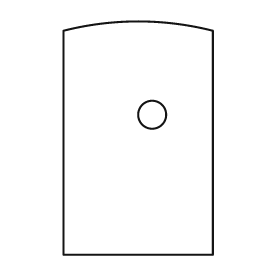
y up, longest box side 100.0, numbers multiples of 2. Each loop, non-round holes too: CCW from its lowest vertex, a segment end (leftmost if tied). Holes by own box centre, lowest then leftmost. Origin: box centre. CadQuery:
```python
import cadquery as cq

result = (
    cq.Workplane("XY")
    .moveTo(-32.0, -50.0)
    .lineTo(32.0, -50.0)
    .lineTo(32.0, 46.0)
    .threePointArc((0.0, 50.0), (-32.0, 46.0))
    .close()
    .moveTo(6.0, 10.0)
    .circle(6.0)
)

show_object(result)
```